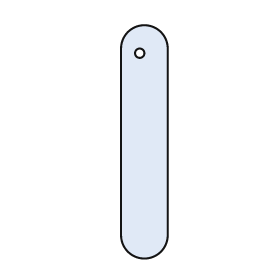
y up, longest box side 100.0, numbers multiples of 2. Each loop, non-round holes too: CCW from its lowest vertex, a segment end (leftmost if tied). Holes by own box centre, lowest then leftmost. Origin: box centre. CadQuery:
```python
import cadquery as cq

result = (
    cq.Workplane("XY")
    .moveTo(-10.0, -40.0)
    .threePointArc((0.0, -50.0), (10.0, -40.0))
    .lineTo(10.0, 40.0)
    .threePointArc((0.0, 50.0), (-10.0, 40.0))
    .close()
    .moveTo(-2.0, 38.0)
    .circle(2.0)
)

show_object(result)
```